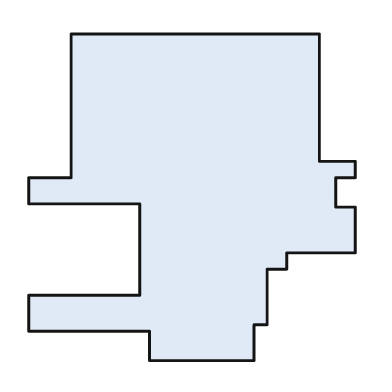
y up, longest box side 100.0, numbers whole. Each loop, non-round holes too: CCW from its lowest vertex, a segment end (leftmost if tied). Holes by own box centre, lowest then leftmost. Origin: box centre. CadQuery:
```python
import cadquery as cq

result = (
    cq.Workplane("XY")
    .moveTo(-13.0, -50.0)
    .lineTo(19.0, -50.0)
    .lineTo(19.0, -39.0)
    .lineTo(23.0, -39.0)
    .lineTo(23.0, -22.0)
    .lineTo(29.0, -22.0)
    .lineTo(29.0, -17.0)
    .lineTo(50.0, -17.0)
    .lineTo(50.0, -3.0)
    .lineTo(44.0, -3.0)
    .lineTo(44.0, 6.0)
    .lineTo(50.0, 6.0)
    .lineTo(50.0, 11.0)
    .lineTo(39.0, 11.0)
    .lineTo(39.0, 50.0)
    .lineTo(-37.0, 50.0)
    .lineTo(-37.0, 6.0)
    .lineTo(-50.0, 6.0)
    .lineTo(-50.0, -2.0)
    .lineTo(-16.0, -2.0)
    .lineTo(-16.0, -30.0)
    .lineTo(-50.0, -30.0)
    .lineTo(-50.0, -41.0)
    .lineTo(-13.0, -41.0)
    .close()
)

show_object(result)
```